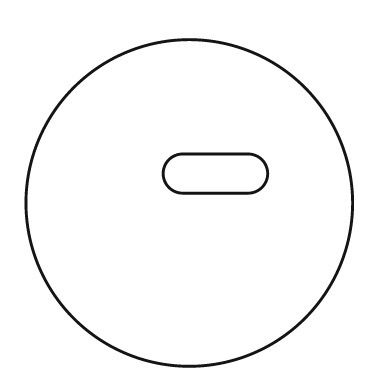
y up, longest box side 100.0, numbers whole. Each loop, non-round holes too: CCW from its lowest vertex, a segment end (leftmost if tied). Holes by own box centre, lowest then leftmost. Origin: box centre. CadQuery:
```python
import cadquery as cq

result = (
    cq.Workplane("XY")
    .moveTo(0.0, 0.0)
    .circle(50.0)
    .moveTo(-2.0, 3.0)
    .lineTo(18.0, 3.0)
    .threePointArc((24.0, 9.0), (18.0, 15.0))
    .lineTo(-2.0, 15.0)
    .threePointArc((-8.0, 9.0), (-2.0, 3.0))
    .close()
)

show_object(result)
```